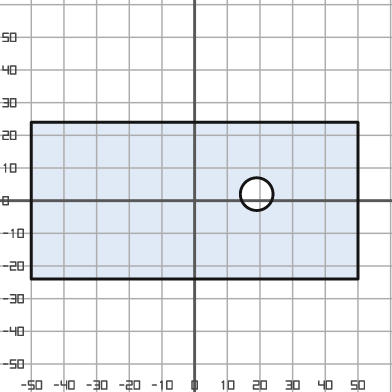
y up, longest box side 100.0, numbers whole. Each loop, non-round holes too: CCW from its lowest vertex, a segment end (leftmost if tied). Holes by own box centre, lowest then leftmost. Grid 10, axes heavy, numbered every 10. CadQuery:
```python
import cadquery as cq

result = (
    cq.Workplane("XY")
    .moveTo(-50.0, -24.0)
    .lineTo(50.0, -24.0)
    .lineTo(50.0, 24.0)
    .lineTo(-50.0, 24.0)
    .close()
    .moveTo(19.0, 2.0)
    .circle(5.0)
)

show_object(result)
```